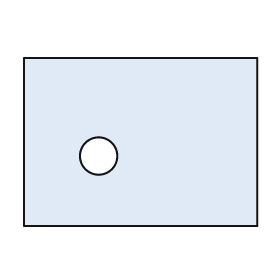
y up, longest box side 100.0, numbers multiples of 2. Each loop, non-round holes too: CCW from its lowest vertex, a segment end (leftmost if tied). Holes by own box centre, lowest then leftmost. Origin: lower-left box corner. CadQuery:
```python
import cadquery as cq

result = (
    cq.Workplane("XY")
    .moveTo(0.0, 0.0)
    .lineTo(100.0, 0.0)
    .lineTo(100.0, 72.0)
    .lineTo(0.0, 72.0)
    .close()
    .moveTo(32.0, 30.0)
    .circle(8.0)
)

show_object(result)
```